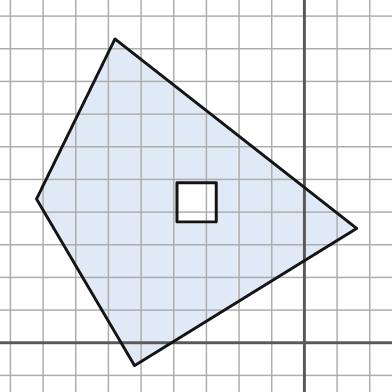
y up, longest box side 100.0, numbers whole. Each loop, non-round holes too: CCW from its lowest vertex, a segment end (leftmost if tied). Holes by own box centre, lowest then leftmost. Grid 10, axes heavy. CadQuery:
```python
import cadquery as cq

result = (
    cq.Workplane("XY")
    .moveTo(-52.0, -7.0)
    .lineTo(16.0, 35.0)
    .lineTo(-58.0, 93.0)
    .lineTo(-82.0, 44.0)
    .close()
    .moveTo(-39.0, 37.0)
    .lineTo(-27.0, 37.0)
    .lineTo(-27.0, 49.0)
    .lineTo(-39.0, 49.0)
    .close()
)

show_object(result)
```